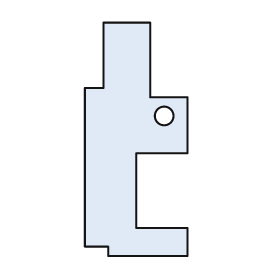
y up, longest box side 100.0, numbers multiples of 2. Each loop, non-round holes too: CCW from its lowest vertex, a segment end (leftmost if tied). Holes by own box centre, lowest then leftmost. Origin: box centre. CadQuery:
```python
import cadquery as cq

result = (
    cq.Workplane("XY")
    .moveTo(-12.0, -50.0)
    .lineTo(22.0, -50.0)
    .lineTo(22.0, -38.0)
    .lineTo(0.0, -38.0)
    .lineTo(0.0, -6.0)
    .lineTo(22.0, -6.0)
    .lineTo(22.0, 18.0)
    .lineTo(6.0, 18.0)
    .lineTo(6.0, 50.0)
    .lineTo(-14.0, 50.0)
    .lineTo(-14.0, 22.0)
    .lineTo(-22.0, 22.0)
    .lineTo(-22.0, -46.0)
    .lineTo(-12.0, -46.0)
    .close()
    .moveTo(12.0, 10.0)
    .circle(4.0)
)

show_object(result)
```